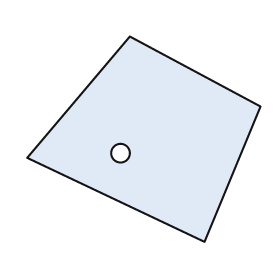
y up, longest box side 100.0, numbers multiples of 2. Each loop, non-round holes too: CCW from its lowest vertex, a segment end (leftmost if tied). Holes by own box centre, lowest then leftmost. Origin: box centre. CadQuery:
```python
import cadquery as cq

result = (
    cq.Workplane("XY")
    .moveTo(26.0, -44.0)
    .lineTo(50.0, 14.0)
    .lineTo(-6.0, 44.0)
    .lineTo(-50.0, -8.0)
    .close()
    .moveTo(-10.0, -6.0)
    .circle(4.0)
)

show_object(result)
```